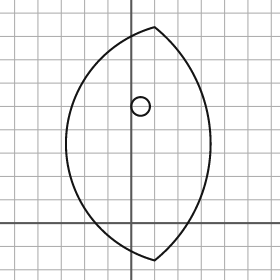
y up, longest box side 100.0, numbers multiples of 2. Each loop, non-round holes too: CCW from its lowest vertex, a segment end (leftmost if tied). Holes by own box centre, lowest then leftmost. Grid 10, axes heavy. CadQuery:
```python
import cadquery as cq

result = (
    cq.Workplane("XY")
    .moveTo(10.0, -16.0)
    .threePointArc((34.0, 34.0), (10.0, 84.0))
    .threePointArc((-28.0, 34.0), (10.0, -16.0))
    .close()
    .moveTo(4.0, 50.0)
    .circle(4.0)
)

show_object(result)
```